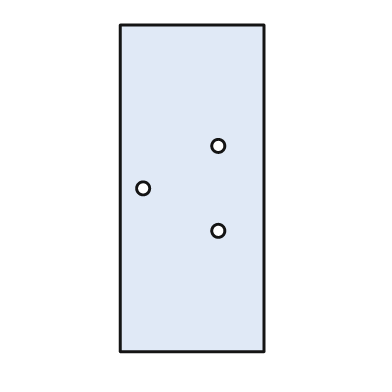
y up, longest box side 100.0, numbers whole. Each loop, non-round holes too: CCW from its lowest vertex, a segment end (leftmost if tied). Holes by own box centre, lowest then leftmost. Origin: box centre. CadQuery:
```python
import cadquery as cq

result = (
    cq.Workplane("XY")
    .moveTo(-22.0, -50.0)
    .lineTo(22.0, -50.0)
    .lineTo(22.0, 50.0)
    .lineTo(-22.0, 50.0)
    .close()
    .moveTo(8.0, -13.0)
    .circle(2.0)
    .moveTo(-15.0, 0.0)
    .circle(2.0)
    .moveTo(8.0, 13.0)
    .circle(2.0)
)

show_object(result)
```